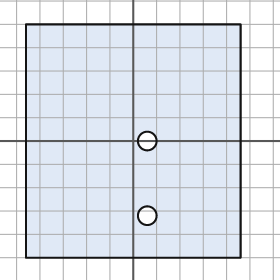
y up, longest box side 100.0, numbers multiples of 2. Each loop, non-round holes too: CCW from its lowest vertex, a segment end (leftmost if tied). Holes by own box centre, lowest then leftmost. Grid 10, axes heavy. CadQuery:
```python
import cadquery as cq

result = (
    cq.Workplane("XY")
    .moveTo(-46.0, -50.0)
    .lineTo(46.0, -50.0)
    .lineTo(46.0, 50.0)
    .lineTo(-46.0, 50.0)
    .close()
    .moveTo(6.0, -32.0)
    .circle(4.0)
    .moveTo(6.0, 0.0)
    .circle(4.0)
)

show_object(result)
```